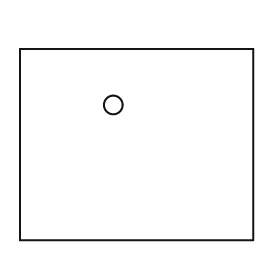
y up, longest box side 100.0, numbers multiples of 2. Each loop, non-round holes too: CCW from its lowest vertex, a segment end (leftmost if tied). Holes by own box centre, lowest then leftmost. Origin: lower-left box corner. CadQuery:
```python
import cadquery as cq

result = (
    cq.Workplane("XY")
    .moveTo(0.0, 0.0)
    .lineTo(100.0, 0.0)
    .lineTo(100.0, 82.0)
    .lineTo(0.0, 82.0)
    .close()
    .moveTo(40.0, 58.0)
    .circle(4.0)
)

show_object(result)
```